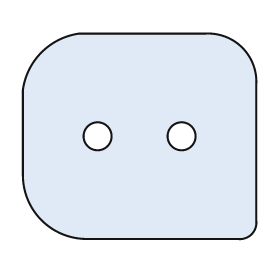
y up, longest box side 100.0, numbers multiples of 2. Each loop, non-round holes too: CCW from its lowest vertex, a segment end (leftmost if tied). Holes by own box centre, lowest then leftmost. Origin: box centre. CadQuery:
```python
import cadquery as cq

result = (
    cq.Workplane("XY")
    .moveTo(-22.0, -44.0)
    .lineTo(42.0, -44.0)
    .threePointArc((48.0, -42.0), (50.0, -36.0))
    .lineTo(50.0, 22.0)
    .threePointArc((44.0, 38.0), (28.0, 44.0))
    .lineTo(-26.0, 44.0)
    .threePointArc((-42.0, 36.0), (-50.0, 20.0))
    .lineTo(-50.0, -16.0)
    .threePointArc((-42.0, -36.0), (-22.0, -44.0))
    .close()
    .moveTo(-18.0, 0.0)
    .circle(6.0)
    .moveTo(18.0, 0.0)
    .circle(6.0)
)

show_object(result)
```